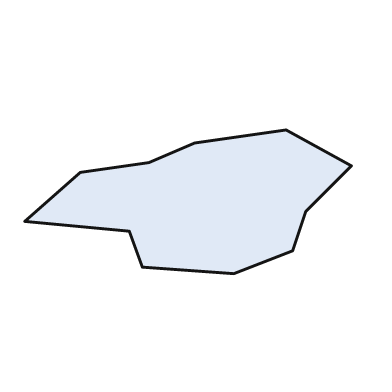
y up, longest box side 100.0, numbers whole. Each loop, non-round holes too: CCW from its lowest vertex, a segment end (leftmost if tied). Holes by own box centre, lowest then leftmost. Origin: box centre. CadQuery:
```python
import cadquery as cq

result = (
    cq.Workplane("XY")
    .moveTo(14.0, -22.0)
    .lineTo(32.0, -15.0)
    .lineTo(36.0, -3.0)
    .lineTo(50.0, 11.0)
    .lineTo(30.0, 22.0)
    .lineTo(2.0, 18.0)
    .lineTo(-12.0, 12.0)
    .lineTo(-33.0, 9.0)
    .lineTo(-50.0, -6.0)
    .lineTo(-18.0, -9.0)
    .lineTo(-14.0, -20.0)
    .close()
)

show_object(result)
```